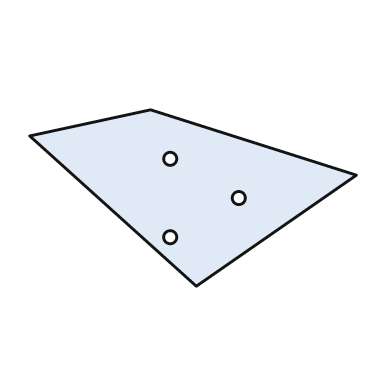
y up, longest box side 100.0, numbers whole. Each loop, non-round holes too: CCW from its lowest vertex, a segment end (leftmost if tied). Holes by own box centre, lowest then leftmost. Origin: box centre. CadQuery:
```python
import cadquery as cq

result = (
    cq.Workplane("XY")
    .moveTo(1.0, -27.0)
    .lineTo(50.0, 7.0)
    .lineTo(-13.0, 27.0)
    .lineTo(-50.0, 19.0)
    .close()
    .moveTo(-7.0, -12.0)
    .circle(2.0)
    .moveTo(14.0, 0.0)
    .circle(2.0)
    .moveTo(-7.0, 12.0)
    .circle(2.0)
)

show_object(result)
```